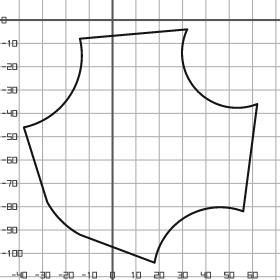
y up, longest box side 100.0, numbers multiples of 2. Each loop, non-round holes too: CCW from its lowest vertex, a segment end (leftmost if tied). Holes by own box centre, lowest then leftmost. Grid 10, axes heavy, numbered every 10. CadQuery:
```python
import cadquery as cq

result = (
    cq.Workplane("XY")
    .moveTo(18.0, -104.0)
    .threePointArc((32.0, -84.0), (56.0, -82.0))
    .lineTo(62.0, -36.0)
    .threePointArc((36.0, -30.0), (32.0, -4.0))
    .lineTo(-14.0, -8.0)
    .threePointArc((-18.0, -32.0), (-38.0, -46.0))
    .lineTo(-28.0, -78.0)
    .threePointArc((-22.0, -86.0), (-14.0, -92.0))
    .close()
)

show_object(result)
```